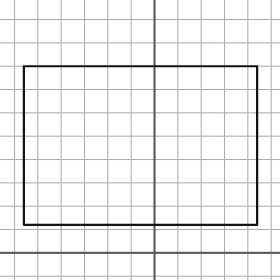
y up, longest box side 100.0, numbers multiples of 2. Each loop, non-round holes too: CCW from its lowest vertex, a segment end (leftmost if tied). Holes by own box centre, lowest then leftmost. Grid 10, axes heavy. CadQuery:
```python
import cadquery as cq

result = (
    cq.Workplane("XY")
    .moveTo(-56.0, 12.0)
    .lineTo(44.0, 12.0)
    .lineTo(44.0, 80.0)
    .lineTo(-56.0, 80.0)
    .close()
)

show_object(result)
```